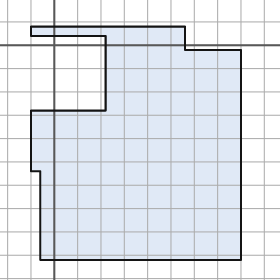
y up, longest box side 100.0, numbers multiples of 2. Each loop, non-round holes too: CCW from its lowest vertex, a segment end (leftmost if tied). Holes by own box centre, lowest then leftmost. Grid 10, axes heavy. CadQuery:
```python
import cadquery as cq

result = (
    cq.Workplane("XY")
    .moveTo(-6.0, -92.0)
    .lineTo(80.0, -92.0)
    .lineTo(80.0, -2.0)
    .lineTo(56.0, -2.0)
    .lineTo(56.0, 8.0)
    .lineTo(-10.0, 8.0)
    .lineTo(-10.0, 4.0)
    .lineTo(22.0, 4.0)
    .lineTo(22.0, -28.0)
    .lineTo(-10.0, -28.0)
    .lineTo(-10.0, -54.0)
    .lineTo(-6.0, -54.0)
    .close()
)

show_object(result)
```